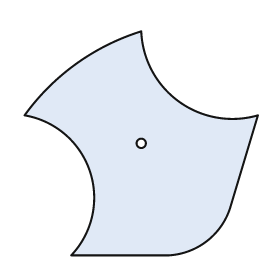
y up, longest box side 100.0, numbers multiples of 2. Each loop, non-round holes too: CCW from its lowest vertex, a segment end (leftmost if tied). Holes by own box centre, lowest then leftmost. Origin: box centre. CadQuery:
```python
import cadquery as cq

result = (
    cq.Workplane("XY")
    .moveTo(-30.0, -48.0)
    .lineTo(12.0, -48.0)
    .threePointArc((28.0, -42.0), (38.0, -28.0))
    .lineTo(50.0, 12.0)
    .threePointArc((16.0, 18.0), (0.0, 48.0))
    .threePointArc((-28.0, 34.0), (-50.0, 12.0))
    .threePointArc((-22.0, -12.0), (-30.0, -48.0))
    .close()
    .moveTo(0.0, 0.0)
    .circle(2.0)
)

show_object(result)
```